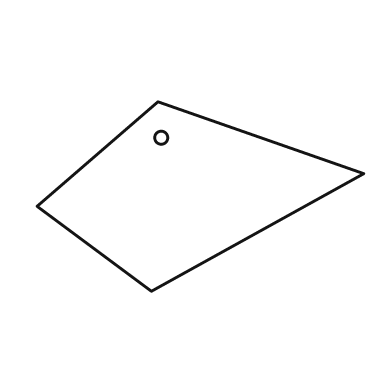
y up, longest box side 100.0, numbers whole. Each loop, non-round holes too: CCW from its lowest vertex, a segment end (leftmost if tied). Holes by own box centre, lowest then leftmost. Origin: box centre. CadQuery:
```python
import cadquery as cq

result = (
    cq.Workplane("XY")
    .moveTo(-15.0, -29.0)
    .lineTo(50.0, 7.0)
    .lineTo(-13.0, 29.0)
    .lineTo(-50.0, -3.0)
    .close()
    .moveTo(-12.0, 18.0)
    .circle(2.0)
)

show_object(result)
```